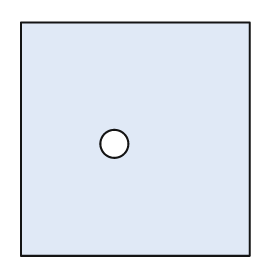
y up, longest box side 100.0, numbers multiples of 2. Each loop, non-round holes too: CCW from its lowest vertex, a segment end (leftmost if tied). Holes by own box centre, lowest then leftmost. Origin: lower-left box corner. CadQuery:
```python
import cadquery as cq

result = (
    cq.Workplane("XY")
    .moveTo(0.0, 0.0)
    .lineTo(98.0, 0.0)
    .lineTo(98.0, 100.0)
    .lineTo(0.0, 100.0)
    .close()
    .moveTo(40.0, 48.0)
    .circle(6.0)
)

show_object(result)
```